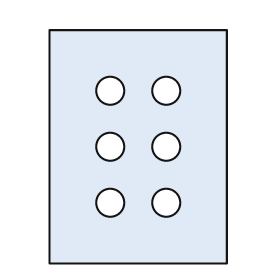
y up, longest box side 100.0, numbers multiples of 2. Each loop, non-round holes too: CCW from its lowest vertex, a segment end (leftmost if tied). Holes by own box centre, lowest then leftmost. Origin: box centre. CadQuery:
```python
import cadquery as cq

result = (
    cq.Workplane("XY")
    .moveTo(-38.0, -50.0)
    .lineTo(38.0, -50.0)
    .lineTo(38.0, 50.0)
    .lineTo(-38.0, 50.0)
    .close()
    .moveTo(-12.0, -24.0)
    .circle(6.0)
    .moveTo(12.0, -24.0)
    .circle(6.0)
    .moveTo(-12.0, 0.0)
    .circle(6.0)
    .moveTo(12.0, 0.0)
    .circle(6.0)
    .moveTo(-12.0, 24.0)
    .circle(6.0)
    .moveTo(12.0, 24.0)
    .circle(6.0)
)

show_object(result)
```